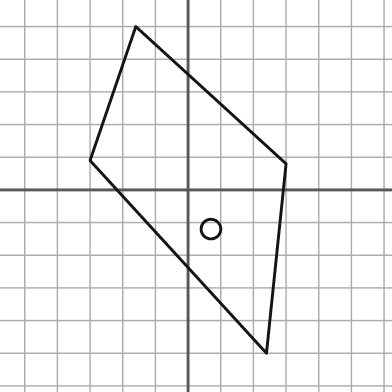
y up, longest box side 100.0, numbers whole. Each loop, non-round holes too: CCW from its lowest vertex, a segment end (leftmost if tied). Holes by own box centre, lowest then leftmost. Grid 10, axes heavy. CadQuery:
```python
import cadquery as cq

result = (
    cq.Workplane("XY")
    .moveTo(24.0, -50.0)
    .lineTo(30.0, 8.0)
    .lineTo(-16.0, 50.0)
    .lineTo(-30.0, 9.0)
    .close()
    .moveTo(7.0, -12.0)
    .circle(3.0)
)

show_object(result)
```